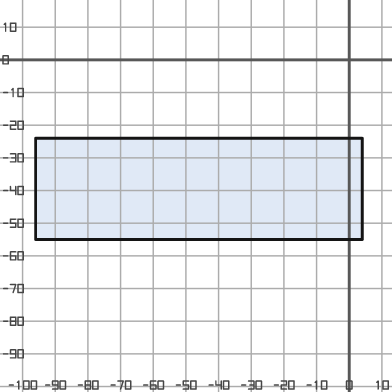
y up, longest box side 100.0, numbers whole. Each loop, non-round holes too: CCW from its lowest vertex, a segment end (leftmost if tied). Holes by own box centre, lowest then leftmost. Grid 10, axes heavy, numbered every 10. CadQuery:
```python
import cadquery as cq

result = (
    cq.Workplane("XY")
    .moveTo(-96.0, -55.0)
    .lineTo(4.0, -55.0)
    .lineTo(4.0, -24.0)
    .lineTo(-96.0, -24.0)
    .close()
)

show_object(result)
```